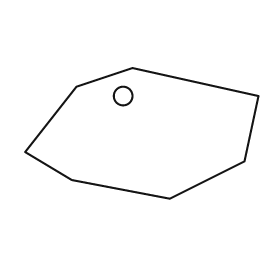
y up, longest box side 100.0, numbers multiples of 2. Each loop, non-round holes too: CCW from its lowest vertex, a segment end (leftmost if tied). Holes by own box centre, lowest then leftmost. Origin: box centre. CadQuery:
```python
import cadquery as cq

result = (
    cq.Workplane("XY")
    .moveTo(12.0, -28.0)
    .lineTo(44.0, -12.0)
    .lineTo(50.0, 16.0)
    .lineTo(-4.0, 28.0)
    .lineTo(-28.0, 20.0)
    .lineTo(-50.0, -8.0)
    .lineTo(-30.0, -20.0)
    .close()
    .moveTo(-8.0, 16.0)
    .circle(4.0)
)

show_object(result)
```